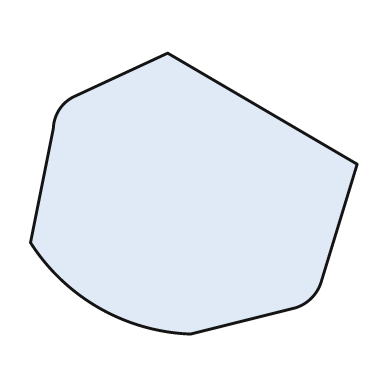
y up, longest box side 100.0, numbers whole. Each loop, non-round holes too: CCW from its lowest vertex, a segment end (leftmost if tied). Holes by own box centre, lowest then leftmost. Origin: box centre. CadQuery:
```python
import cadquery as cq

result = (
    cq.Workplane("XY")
    .moveTo(-1.0, -43.0)
    .lineTo(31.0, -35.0)
    .threePointArc((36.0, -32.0), (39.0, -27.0))
    .lineTo(50.0, 9.0)
    .lineTo(-8.0, 43.0)
    .lineTo(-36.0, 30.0)
    .threePointArc((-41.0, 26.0), (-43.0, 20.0))
    .lineTo(-50.0, -15.0)
    .threePointArc((-29.0, -35.0), (-1.0, -43.0))
    .close()
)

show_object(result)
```